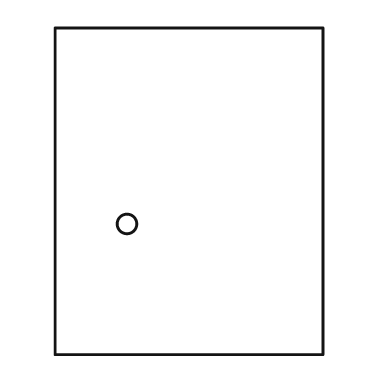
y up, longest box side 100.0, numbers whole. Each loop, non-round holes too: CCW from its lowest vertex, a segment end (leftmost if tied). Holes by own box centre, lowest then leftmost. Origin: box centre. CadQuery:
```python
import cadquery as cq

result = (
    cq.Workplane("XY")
    .moveTo(-41.0, -50.0)
    .lineTo(41.0, -50.0)
    .lineTo(41.0, 50.0)
    .lineTo(-41.0, 50.0)
    .close()
    .moveTo(-19.0, -10.0)
    .circle(3.0)
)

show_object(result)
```